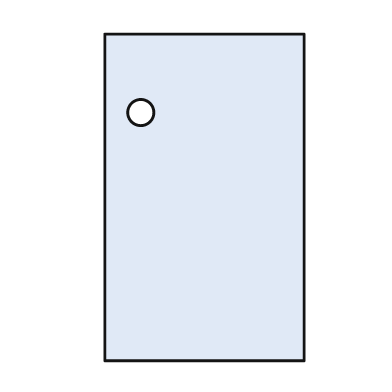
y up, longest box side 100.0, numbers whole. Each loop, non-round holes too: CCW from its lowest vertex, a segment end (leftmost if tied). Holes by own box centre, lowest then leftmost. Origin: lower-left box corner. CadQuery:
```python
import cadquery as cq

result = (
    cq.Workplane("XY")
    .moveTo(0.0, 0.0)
    .lineTo(61.0, 0.0)
    .lineTo(61.0, 100.0)
    .lineTo(0.0, 100.0)
    .close()
    .moveTo(11.0, 76.0)
    .circle(4.0)
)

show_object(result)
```